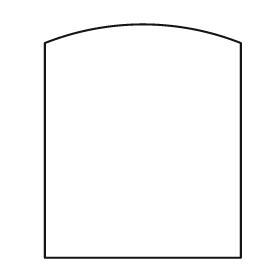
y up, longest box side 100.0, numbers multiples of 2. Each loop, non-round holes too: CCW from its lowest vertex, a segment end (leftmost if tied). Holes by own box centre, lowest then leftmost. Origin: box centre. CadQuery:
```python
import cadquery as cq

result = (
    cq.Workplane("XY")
    .moveTo(-42.0, -50.0)
    .lineTo(42.0, -50.0)
    .lineTo(42.0, 42.0)
    .threePointArc((0.0, 50.0), (-42.0, 42.0))
    .close()
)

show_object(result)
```